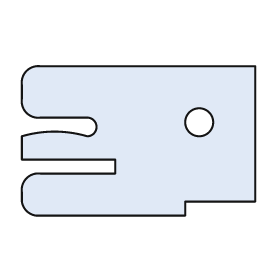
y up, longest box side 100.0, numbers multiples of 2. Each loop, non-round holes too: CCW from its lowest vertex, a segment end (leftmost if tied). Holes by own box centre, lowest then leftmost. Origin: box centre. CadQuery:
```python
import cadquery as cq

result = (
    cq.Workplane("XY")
    .moveTo(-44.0, -32.0)
    .lineTo(20.0, -32.0)
    .lineTo(20.0, -26.0)
    .lineTo(50.0, -26.0)
    .lineTo(50.0, 32.0)
    .lineTo(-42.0, 32.0)
    .threePointArc((-48.0, 30.0), (-50.0, 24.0))
    .lineTo(-50.0, 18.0)
    .threePointArc((-48.0, 12.0), (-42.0, 10.0))
    .lineTo(-22.0, 10.0)
    .threePointArc((-18.0, 6.0), (-22.0, 2.0))
    .threePointArc((-36.0, 4.0), (-50.0, 2.0))
    .lineTo(-50.0, -8.0)
    .lineTo(-10.0, -8.0)
    .lineTo(-10.0, -14.0)
    .lineTo(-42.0, -14.0)
    .threePointArc((-48.0, -16.0), (-50.0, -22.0))
    .lineTo(-50.0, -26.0)
    .threePointArc((-48.0, -30.0), (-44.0, -32.0))
    .close()
    .moveTo(26.0, 8.0)
    .circle(6.0)
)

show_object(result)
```